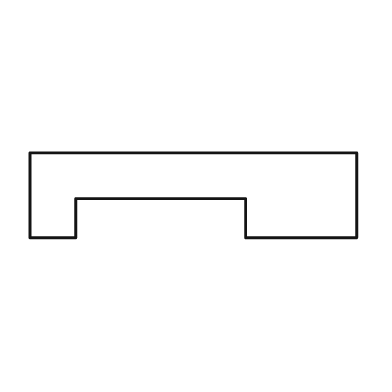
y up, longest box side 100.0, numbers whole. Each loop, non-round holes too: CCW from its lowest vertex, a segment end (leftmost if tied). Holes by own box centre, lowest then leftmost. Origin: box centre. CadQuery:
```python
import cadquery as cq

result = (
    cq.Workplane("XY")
    .moveTo(-50.0, -13.0)
    .lineTo(-36.0, -13.0)
    .lineTo(-36.0, -1.0)
    .lineTo(16.0, -1.0)
    .lineTo(16.0, -13.0)
    .lineTo(50.0, -13.0)
    .lineTo(50.0, 13.0)
    .lineTo(-50.0, 13.0)
    .close()
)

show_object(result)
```